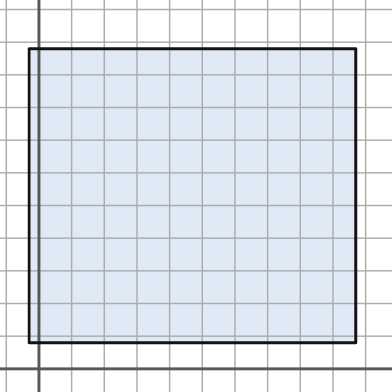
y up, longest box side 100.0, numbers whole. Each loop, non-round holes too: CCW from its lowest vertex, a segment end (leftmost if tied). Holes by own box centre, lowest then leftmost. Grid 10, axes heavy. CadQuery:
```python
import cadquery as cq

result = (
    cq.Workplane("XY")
    .moveTo(-3.0, 8.0)
    .lineTo(97.0, 8.0)
    .lineTo(97.0, 98.0)
    .lineTo(-3.0, 98.0)
    .close()
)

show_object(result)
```